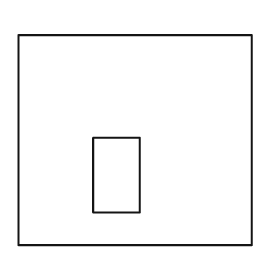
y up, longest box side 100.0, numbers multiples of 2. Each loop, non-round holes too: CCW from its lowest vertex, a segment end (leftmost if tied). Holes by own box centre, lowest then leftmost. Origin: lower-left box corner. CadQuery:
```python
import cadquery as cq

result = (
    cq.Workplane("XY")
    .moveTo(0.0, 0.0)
    .lineTo(100.0, 0.0)
    .lineTo(100.0, 90.0)
    .lineTo(0.0, 90.0)
    .close()
    .moveTo(32.0, 14.0)
    .lineTo(52.0, 14.0)
    .lineTo(52.0, 46.0)
    .lineTo(32.0, 46.0)
    .close()
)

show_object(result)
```